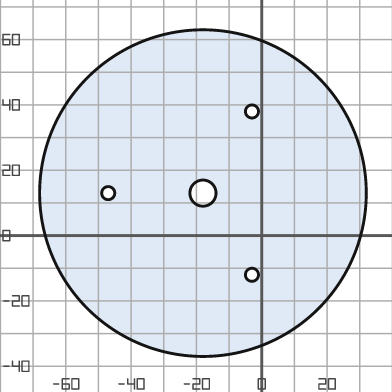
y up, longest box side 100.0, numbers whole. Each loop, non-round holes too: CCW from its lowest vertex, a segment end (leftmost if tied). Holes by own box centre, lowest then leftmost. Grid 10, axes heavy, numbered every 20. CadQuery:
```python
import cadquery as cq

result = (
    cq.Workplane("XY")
    .moveTo(-18.0, 13.0)
    .circle(50.0)
    .moveTo(-3.0, -12.0)
    .circle(2.0)
    .moveTo(-47.0, 13.0)
    .circle(2.0)
    .moveTo(-18.0, 13.0)
    .circle(4.0)
    .moveTo(-3.0, 38.0)
    .circle(2.0)
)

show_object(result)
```